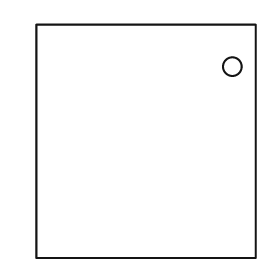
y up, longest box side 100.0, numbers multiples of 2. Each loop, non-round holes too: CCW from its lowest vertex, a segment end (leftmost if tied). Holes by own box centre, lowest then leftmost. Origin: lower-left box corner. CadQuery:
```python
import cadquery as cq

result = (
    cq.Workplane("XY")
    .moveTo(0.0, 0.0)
    .lineTo(94.0, 0.0)
    .lineTo(94.0, 100.0)
    .lineTo(0.0, 100.0)
    .close()
    .moveTo(84.0, 82.0)
    .circle(4.0)
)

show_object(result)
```